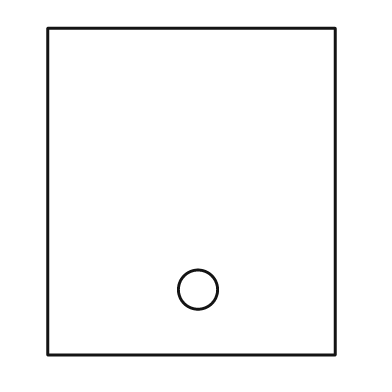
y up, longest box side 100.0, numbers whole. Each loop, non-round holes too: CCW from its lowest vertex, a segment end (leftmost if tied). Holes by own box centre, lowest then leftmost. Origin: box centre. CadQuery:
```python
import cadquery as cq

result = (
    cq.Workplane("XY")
    .moveTo(-44.0, -50.0)
    .lineTo(44.0, -50.0)
    .lineTo(44.0, 50.0)
    .lineTo(-44.0, 50.0)
    .close()
    .moveTo(2.0, -30.0)
    .circle(6.0)
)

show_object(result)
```